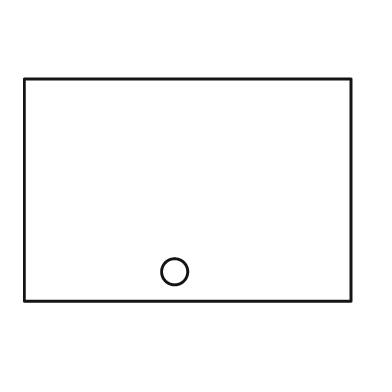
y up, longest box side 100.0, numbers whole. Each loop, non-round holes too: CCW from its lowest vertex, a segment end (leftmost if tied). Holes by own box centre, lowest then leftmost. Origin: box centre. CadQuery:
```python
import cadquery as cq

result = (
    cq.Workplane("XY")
    .moveTo(-50.0, -34.0)
    .lineTo(50.0, -34.0)
    .lineTo(50.0, 34.0)
    .lineTo(-50.0, 34.0)
    .close()
    .moveTo(-4.0, -25.0)
    .circle(4.0)
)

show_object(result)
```